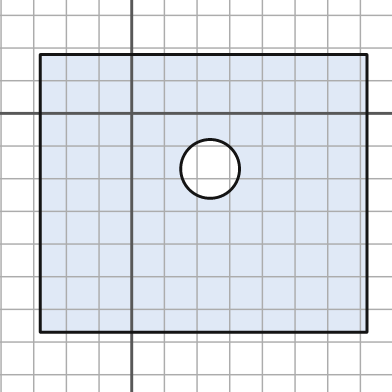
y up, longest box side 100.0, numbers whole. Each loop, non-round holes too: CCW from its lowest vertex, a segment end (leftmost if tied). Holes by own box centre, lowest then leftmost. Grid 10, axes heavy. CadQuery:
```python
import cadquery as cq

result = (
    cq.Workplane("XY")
    .moveTo(-28.0, -67.0)
    .lineTo(72.0, -67.0)
    .lineTo(72.0, 18.0)
    .lineTo(-28.0, 18.0)
    .close()
    .moveTo(24.0, -17.0)
    .circle(9.0)
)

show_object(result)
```